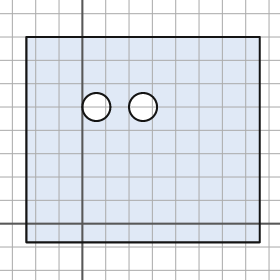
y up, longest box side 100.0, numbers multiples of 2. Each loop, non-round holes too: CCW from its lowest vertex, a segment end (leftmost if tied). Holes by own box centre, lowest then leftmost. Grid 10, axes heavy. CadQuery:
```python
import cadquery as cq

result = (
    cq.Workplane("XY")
    .moveTo(-24.0, -8.0)
    .lineTo(76.0, -8.0)
    .lineTo(76.0, 80.0)
    .lineTo(-24.0, 80.0)
    .close()
    .moveTo(6.0, 50.0)
    .circle(6.0)
    .moveTo(26.0, 50.0)
    .circle(6.0)
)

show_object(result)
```